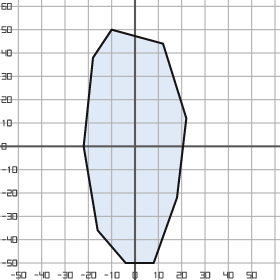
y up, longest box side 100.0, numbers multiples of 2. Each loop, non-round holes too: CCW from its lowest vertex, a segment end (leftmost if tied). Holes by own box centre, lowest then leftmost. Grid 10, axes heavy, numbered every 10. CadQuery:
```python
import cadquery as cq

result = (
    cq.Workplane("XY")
    .moveTo(-4.0, -50.0)
    .lineTo(8.0, -50.0)
    .lineTo(18.0, -22.0)
    .lineTo(22.0, 12.0)
    .lineTo(12.0, 44.0)
    .lineTo(-10.0, 50.0)
    .lineTo(-18.0, 38.0)
    .lineTo(-22.0, 0.0)
    .lineTo(-16.0, -36.0)
    .close()
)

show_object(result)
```